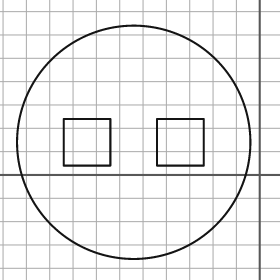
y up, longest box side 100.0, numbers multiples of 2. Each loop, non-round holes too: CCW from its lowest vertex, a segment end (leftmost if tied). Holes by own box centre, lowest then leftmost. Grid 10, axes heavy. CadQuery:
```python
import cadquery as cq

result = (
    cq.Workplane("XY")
    .moveTo(-54.0, 14.0)
    .circle(50.0)
    .moveTo(-84.0, 4.0)
    .lineTo(-64.0, 4.0)
    .lineTo(-64.0, 24.0)
    .lineTo(-84.0, 24.0)
    .close()
    .moveTo(-44.0, 4.0)
    .lineTo(-24.0, 4.0)
    .lineTo(-24.0, 24.0)
    .lineTo(-44.0, 24.0)
    .close()
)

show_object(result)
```